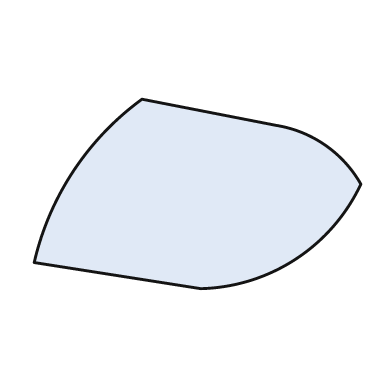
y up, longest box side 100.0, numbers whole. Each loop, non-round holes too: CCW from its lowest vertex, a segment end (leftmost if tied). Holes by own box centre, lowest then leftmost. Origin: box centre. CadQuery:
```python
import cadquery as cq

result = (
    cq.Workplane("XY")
    .moveTo(1.0, -29.0)
    .threePointArc((30.0, -20.0), (50.0, 3.0))
    .threePointArc((39.0, 15.0), (24.0, 21.0))
    .lineTo(-17.0, 29.0)
    .threePointArc((-38.0, 7.0), (-50.0, -21.0))
    .close()
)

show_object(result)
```